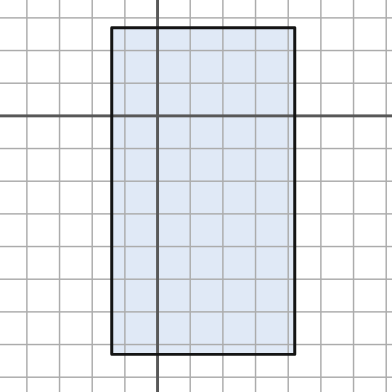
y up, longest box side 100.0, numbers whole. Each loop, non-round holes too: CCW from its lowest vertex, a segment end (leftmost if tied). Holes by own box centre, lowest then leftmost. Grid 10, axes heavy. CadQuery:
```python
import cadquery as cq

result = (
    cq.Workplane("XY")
    .moveTo(-14.0, -73.0)
    .lineTo(42.0, -73.0)
    .lineTo(42.0, 27.0)
    .lineTo(-14.0, 27.0)
    .close()
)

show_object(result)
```